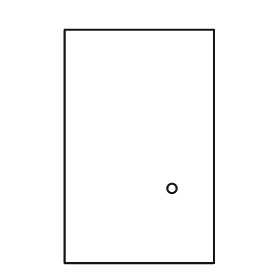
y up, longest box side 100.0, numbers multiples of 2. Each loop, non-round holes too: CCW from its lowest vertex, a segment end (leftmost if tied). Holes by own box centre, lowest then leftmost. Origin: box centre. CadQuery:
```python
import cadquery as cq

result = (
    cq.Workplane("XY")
    .moveTo(-32.0, -50.0)
    .lineTo(32.0, -50.0)
    .lineTo(32.0, 50.0)
    .lineTo(-32.0, 50.0)
    .close()
    .moveTo(14.0, -18.0)
    .circle(2.0)
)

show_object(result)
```